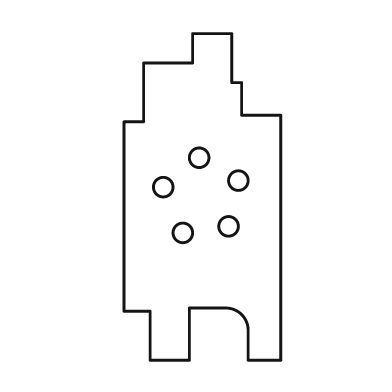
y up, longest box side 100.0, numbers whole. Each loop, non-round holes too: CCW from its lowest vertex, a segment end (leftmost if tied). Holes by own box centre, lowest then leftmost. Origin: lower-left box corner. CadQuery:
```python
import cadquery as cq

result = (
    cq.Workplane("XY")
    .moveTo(8.0, 0.0)
    .lineTo(20.0, 0.0)
    .lineTo(20.0, 16.0)
    .lineTo(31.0, 16.0)
    .threePointArc((36.0, 14.0), (38.0, 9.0))
    .lineTo(38.0, 0.0)
    .lineTo(48.0, 0.0)
    .lineTo(48.0, 75.0)
    .lineTo(36.0, 75.0)
    .lineTo(36.0, 85.0)
    .lineTo(33.0, 85.0)
    .lineTo(33.0, 100.0)
    .lineTo(21.0, 100.0)
    .lineTo(21.0, 91.0)
    .lineTo(6.0, 91.0)
    .lineTo(6.0, 73.0)
    .lineTo(0.0, 73.0)
    .lineTo(0.0, 15.0)
    .lineTo(8.0, 15.0)
    .close()
    .moveTo(18.0, 39.0)
    .circle(3.0)
    .moveTo(32.0, 41.0)
    .circle(3.0)
    .moveTo(12.0, 53.0)
    .circle(3.0)
    .moveTo(35.0, 55.0)
    .circle(3.0)
    .moveTo(23.0, 62.0)
    .circle(3.0)
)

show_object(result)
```